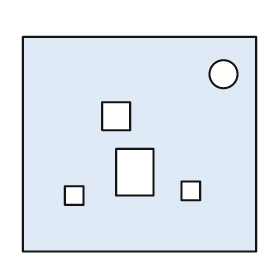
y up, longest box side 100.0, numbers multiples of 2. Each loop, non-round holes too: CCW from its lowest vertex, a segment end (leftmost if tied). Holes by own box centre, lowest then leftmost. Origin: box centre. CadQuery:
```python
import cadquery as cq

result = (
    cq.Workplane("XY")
    .moveTo(-50.0, -46.0)
    .lineTo(50.0, -46.0)
    .lineTo(50.0, 46.0)
    .lineTo(-50.0, 46.0)
    .close()
    .moveTo(-32.0, -26.0)
    .lineTo(-24.0, -26.0)
    .lineTo(-24.0, -18.0)
    .lineTo(-32.0, -18.0)
    .close()
    .moveTo(18.0, -24.0)
    .lineTo(26.0, -24.0)
    .lineTo(26.0, -16.0)
    .lineTo(18.0, -16.0)
    .close()
    .moveTo(-10.0, -22.0)
    .lineTo(6.0, -22.0)
    .lineTo(6.0, -2.0)
    .lineTo(-10.0, -2.0)
    .close()
    .moveTo(-16.0, 6.0)
    .lineTo(-4.0, 6.0)
    .lineTo(-4.0, 18.0)
    .lineTo(-16.0, 18.0)
    .close()
    .moveTo(36.0, 30.0)
    .circle(6.0)
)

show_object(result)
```